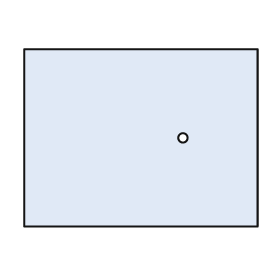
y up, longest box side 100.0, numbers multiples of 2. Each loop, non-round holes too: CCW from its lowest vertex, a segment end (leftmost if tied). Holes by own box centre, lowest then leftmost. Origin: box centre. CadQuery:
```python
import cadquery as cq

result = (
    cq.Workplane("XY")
    .moveTo(-50.0, -38.0)
    .lineTo(50.0, -38.0)
    .lineTo(50.0, 38.0)
    .lineTo(-50.0, 38.0)
    .close()
    .moveTo(18.0, 0.0)
    .circle(2.0)
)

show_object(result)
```